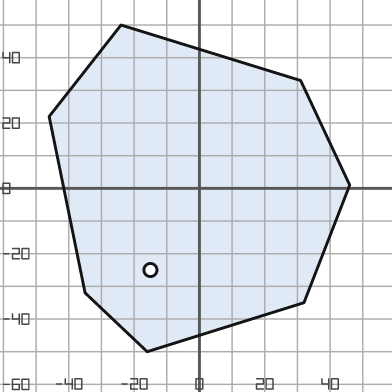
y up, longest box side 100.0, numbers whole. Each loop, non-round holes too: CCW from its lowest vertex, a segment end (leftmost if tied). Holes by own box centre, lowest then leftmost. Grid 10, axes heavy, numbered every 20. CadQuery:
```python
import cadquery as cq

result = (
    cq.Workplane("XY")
    .moveTo(-16.0, -50.0)
    .lineTo(32.0, -35.0)
    .lineTo(46.0, 1.0)
    .lineTo(31.0, 33.0)
    .lineTo(-24.0, 50.0)
    .lineTo(-46.0, 22.0)
    .lineTo(-35.0, -32.0)
    .close()
    .moveTo(-15.0, -25.0)
    .circle(2.0)
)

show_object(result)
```